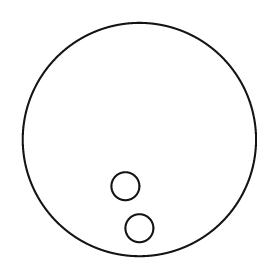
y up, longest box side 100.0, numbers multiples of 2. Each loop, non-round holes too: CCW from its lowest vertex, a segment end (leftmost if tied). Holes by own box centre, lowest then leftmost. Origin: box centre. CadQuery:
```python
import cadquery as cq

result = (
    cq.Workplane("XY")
    .moveTo(0.0, 0.0)
    .circle(50.0)
    .moveTo(0.0, -38.0)
    .circle(6.0)
    .moveTo(-6.0, -20.0)
    .circle(6.0)
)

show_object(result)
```